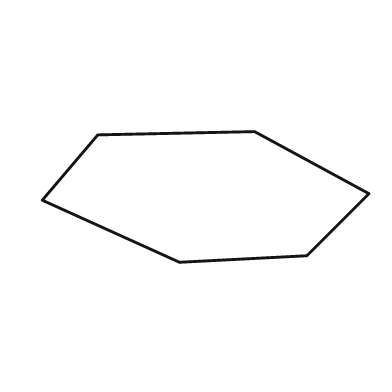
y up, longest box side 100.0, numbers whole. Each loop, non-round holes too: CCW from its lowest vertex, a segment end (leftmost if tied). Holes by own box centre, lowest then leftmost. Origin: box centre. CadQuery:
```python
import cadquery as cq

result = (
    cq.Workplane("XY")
    .moveTo(-8.0, -20.0)
    .lineTo(31.0, -18.0)
    .lineTo(50.0, 1.0)
    .lineTo(15.0, 20.0)
    .lineTo(-33.0, 19.0)
    .lineTo(-50.0, -1.0)
    .close()
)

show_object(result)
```